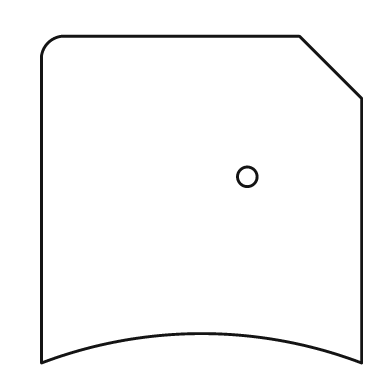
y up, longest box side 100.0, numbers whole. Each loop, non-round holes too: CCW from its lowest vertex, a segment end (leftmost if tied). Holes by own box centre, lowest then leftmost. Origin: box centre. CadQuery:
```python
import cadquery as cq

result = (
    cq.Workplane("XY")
    .moveTo(-49.0, -50.0)
    .threePointArc((0.0, -41.0), (49.0, -50.0))
    .lineTo(49.0, 31.0)
    .lineTo(30.0, 50.0)
    .lineTo(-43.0, 50.0)
    .threePointArc((-47.0, 48.0), (-49.0, 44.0))
    .close()
    .moveTo(14.0, 7.0)
    .circle(3.0)
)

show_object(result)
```